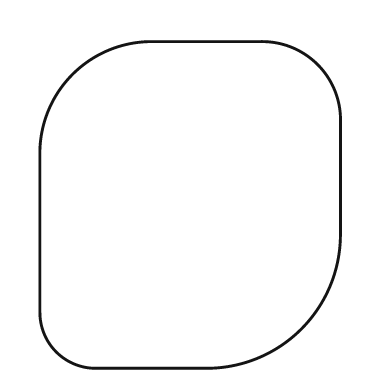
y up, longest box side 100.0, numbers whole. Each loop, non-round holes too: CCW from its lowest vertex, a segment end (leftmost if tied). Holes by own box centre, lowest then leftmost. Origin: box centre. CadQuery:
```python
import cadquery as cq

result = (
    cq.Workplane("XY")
    .moveTo(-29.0, -50.0)
    .lineTo(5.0, -50.0)
    .threePointArc((34.0, -38.0), (46.0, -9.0))
    .lineTo(46.0, 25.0)
    .threePointArc((39.0, 43.0), (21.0, 50.0))
    .lineTo(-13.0, 50.0)
    .threePointArc((-36.0, 40.0), (-46.0, 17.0))
    .lineTo(-46.0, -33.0)
    .threePointArc((-41.0, -45.0), (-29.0, -50.0))
    .close()
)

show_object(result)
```